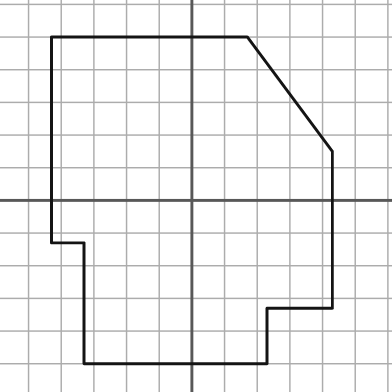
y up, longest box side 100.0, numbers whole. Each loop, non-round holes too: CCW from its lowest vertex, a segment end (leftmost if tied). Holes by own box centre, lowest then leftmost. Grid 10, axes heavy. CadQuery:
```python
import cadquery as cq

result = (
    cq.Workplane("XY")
    .moveTo(-33.0, -50.0)
    .lineTo(23.0, -50.0)
    .lineTo(23.0, -33.0)
    .lineTo(43.0, -33.0)
    .lineTo(43.0, 15.0)
    .lineTo(17.0, 50.0)
    .lineTo(-43.0, 50.0)
    .lineTo(-43.0, -13.0)
    .lineTo(-33.0, -13.0)
    .close()
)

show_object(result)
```